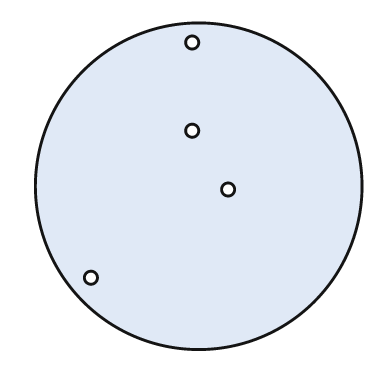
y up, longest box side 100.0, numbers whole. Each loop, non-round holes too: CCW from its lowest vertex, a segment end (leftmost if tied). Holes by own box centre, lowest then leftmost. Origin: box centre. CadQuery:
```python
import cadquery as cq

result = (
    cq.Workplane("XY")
    .moveTo(0.0, 0.0)
    .circle(50.0)
    .moveTo(-33.0, -28.0)
    .circle(2.0)
    .moveTo(9.0, -1.0)
    .circle(2.0)
    .moveTo(-2.0, 17.0)
    .circle(2.0)
    .moveTo(-2.0, 44.0)
    .circle(2.0)
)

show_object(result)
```